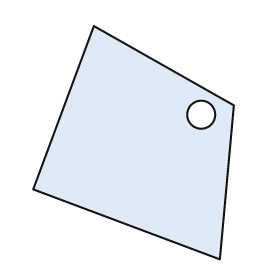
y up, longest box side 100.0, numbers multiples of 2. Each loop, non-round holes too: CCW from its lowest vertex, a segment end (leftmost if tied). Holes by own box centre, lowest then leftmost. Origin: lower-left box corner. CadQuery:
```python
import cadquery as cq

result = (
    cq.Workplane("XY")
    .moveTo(80.0, 0.0)
    .lineTo(86.0, 66.0)
    .lineTo(26.0, 100.0)
    .lineTo(0.0, 30.0)
    .close()
    .moveTo(72.0, 62.0)
    .circle(6.0)
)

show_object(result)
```